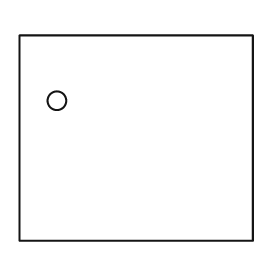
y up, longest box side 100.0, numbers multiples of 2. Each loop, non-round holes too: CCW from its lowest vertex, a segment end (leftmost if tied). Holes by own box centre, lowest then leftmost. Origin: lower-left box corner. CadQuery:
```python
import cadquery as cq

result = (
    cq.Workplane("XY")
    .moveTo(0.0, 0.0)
    .lineTo(100.0, 0.0)
    .lineTo(100.0, 88.0)
    .lineTo(0.0, 88.0)
    .close()
    .moveTo(16.0, 60.0)
    .circle(4.0)
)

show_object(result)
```